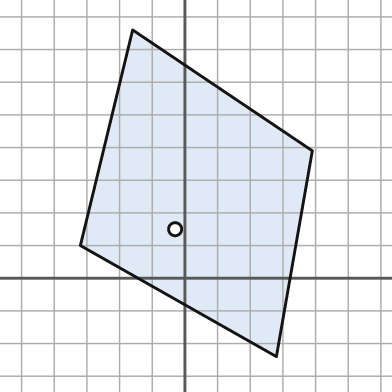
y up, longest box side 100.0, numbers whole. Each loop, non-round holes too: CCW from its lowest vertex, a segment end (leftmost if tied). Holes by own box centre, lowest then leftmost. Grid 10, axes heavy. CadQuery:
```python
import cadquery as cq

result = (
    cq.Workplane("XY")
    .moveTo(28.0, -24.0)
    .lineTo(39.0, 39.0)
    .lineTo(-16.0, 76.0)
    .lineTo(-32.0, 10.0)
    .close()
    .moveTo(-3.0, 15.0)
    .circle(2.0)
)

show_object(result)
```